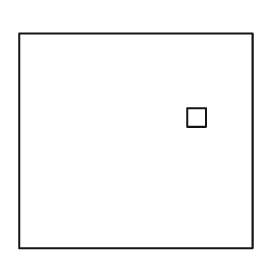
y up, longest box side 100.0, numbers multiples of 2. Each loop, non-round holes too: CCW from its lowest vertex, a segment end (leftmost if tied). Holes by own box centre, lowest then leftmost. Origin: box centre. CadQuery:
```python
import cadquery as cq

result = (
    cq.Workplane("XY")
    .moveTo(-50.0, -46.0)
    .lineTo(50.0, -46.0)
    .lineTo(50.0, 46.0)
    .lineTo(-50.0, 46.0)
    .close()
    .moveTo(22.0, 6.0)
    .lineTo(30.0, 6.0)
    .lineTo(30.0, 14.0)
    .lineTo(22.0, 14.0)
    .close()
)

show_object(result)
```